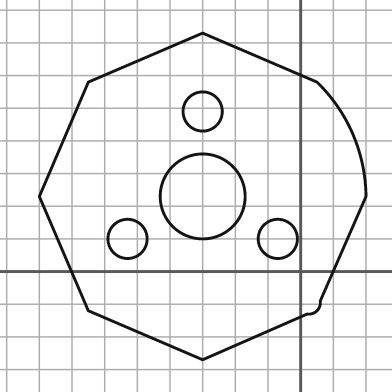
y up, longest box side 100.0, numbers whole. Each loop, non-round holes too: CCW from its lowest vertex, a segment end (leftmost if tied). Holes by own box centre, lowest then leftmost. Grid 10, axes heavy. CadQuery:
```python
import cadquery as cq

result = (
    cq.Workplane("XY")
    .moveTo(-30.0, -27.0)
    .lineTo(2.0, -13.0)
    .threePointArc((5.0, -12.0), (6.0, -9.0))
    .lineTo(20.0, 23.0)
    .threePointArc((16.0, 42.0), (5.0, 58.0))
    .lineTo(-30.0, 73.0)
    .lineTo(-65.0, 58.0)
    .lineTo(-80.0, 23.0)
    .lineTo(-65.0, -12.0)
    .close()
    .moveTo(-53.0, 10.0)
    .circle(6.0)
    .moveTo(-7.0, 10.0)
    .circle(6.0)
    .moveTo(-30.0, 23.0)
    .circle(13.0)
    .moveTo(-30.0, 49.0)
    .circle(6.0)
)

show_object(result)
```